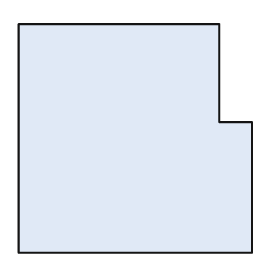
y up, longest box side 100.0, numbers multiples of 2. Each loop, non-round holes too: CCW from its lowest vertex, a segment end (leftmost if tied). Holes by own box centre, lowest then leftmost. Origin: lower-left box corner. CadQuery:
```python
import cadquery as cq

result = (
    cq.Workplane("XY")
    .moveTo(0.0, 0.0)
    .lineTo(100.0, 0.0)
    .lineTo(100.0, 56.0)
    .lineTo(86.0, 56.0)
    .lineTo(86.0, 98.0)
    .lineTo(0.0, 98.0)
    .close()
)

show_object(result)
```